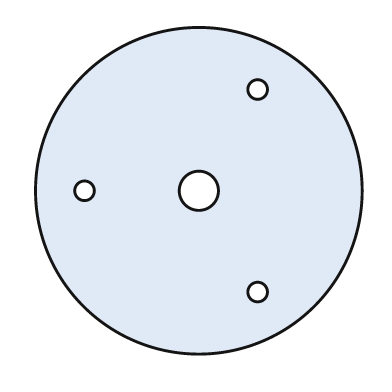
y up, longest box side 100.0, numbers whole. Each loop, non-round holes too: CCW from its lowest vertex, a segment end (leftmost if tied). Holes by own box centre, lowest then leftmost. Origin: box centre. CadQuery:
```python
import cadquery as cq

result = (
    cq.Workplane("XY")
    .moveTo(0.0, 0.0)
    .circle(50.0)
    .moveTo(18.0, -31.0)
    .circle(3.0)
    .moveTo(-35.0, 0.0)
    .circle(3.0)
    .moveTo(0.0, 0.0)
    .circle(6.0)
    .moveTo(18.0, 31.0)
    .circle(3.0)
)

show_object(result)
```